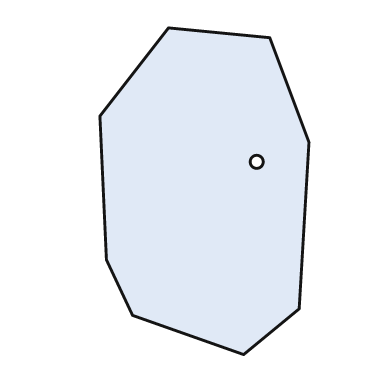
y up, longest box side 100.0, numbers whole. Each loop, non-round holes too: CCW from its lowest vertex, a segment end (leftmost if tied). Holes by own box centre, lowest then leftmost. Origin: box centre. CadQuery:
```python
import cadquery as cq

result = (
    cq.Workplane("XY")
    .moveTo(12.0, -50.0)
    .lineTo(29.0, -36.0)
    .lineTo(32.0, 15.0)
    .lineTo(20.0, 47.0)
    .lineTo(-11.0, 50.0)
    .lineTo(-32.0, 23.0)
    .lineTo(-30.0, -21.0)
    .lineTo(-22.0, -38.0)
    .close()
    .moveTo(16.0, 9.0)
    .circle(2.0)
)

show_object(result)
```